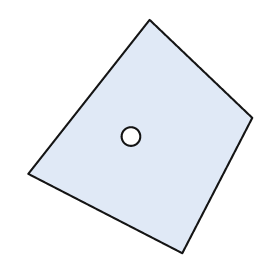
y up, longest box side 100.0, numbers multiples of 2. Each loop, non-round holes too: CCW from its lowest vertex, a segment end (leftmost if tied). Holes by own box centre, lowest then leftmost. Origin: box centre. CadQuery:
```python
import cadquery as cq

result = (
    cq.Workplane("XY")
    .moveTo(18.0, -50.0)
    .lineTo(48.0, 8.0)
    .lineTo(4.0, 50.0)
    .lineTo(-48.0, -16.0)
    .close()
    .moveTo(-4.0, 0.0)
    .circle(4.0)
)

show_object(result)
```